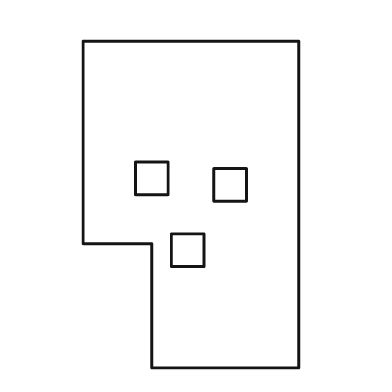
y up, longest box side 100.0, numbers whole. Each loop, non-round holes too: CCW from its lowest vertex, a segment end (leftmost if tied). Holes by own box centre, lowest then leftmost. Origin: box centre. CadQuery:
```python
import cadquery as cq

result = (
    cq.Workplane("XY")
    .moveTo(-12.0, -50.0)
    .lineTo(33.0, -50.0)
    .lineTo(33.0, 50.0)
    .lineTo(-33.0, 50.0)
    .lineTo(-33.0, -12.0)
    .lineTo(-12.0, -12.0)
    .close()
    .moveTo(-6.0, -19.0)
    .lineTo(4.0, -19.0)
    .lineTo(4.0, -9.0)
    .lineTo(-6.0, -9.0)
    .close()
    .moveTo(7.0, 1.0)
    .lineTo(17.0, 1.0)
    .lineTo(17.0, 11.0)
    .lineTo(7.0, 11.0)
    .close()
    .moveTo(-17.0, 3.0)
    .lineTo(-7.0, 3.0)
    .lineTo(-7.0, 13.0)
    .lineTo(-17.0, 13.0)
    .close()
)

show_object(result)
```